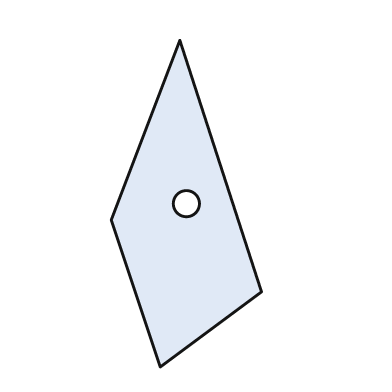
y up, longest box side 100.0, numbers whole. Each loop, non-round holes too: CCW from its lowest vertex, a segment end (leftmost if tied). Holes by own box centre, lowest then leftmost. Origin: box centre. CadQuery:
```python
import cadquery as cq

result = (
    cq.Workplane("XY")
    .moveTo(-8.0, -50.0)
    .lineTo(23.0, -27.0)
    .lineTo(-2.0, 50.0)
    .lineTo(-23.0, -5.0)
    .close()
    .moveTo(0.0, 0.0)
    .circle(4.0)
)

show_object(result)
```